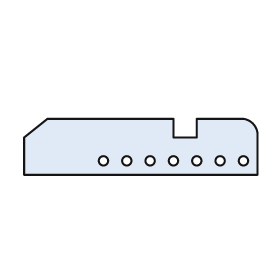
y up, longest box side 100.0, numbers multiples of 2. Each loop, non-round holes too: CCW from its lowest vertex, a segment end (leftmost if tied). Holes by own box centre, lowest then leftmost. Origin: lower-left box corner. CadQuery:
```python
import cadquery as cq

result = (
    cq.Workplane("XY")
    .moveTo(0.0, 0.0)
    .lineTo(100.0, 0.0)
    .lineTo(100.0, 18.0)
    .threePointArc((98.0, 22.0), (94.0, 24.0))
    .lineTo(74.0, 24.0)
    .lineTo(74.0, 16.0)
    .lineTo(64.0, 16.0)
    .lineTo(64.0, 24.0)
    .lineTo(10.0, 24.0)
    .lineTo(0.0, 16.0)
    .close()
    .moveTo(34.0, 6.0)
    .circle(2.0)
    .moveTo(44.0, 6.0)
    .circle(2.0)
    .moveTo(54.0, 6.0)
    .circle(2.0)
    .moveTo(64.0, 6.0)
    .circle(2.0)
    .moveTo(74.0, 6.0)
    .circle(2.0)
    .moveTo(84.0, 6.0)
    .circle(2.0)
    .moveTo(94.0, 6.0)
    .circle(2.0)
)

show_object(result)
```